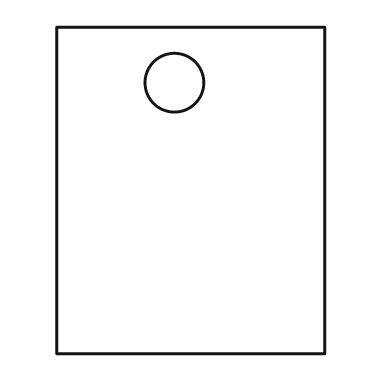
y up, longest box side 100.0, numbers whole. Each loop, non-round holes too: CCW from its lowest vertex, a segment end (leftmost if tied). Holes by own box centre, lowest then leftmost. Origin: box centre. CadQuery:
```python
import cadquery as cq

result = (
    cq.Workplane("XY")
    .moveTo(-41.0, -50.0)
    .lineTo(41.0, -50.0)
    .lineTo(41.0, 50.0)
    .lineTo(-41.0, 50.0)
    .close()
    .moveTo(-5.0, 33.0)
    .circle(9.0)
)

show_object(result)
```